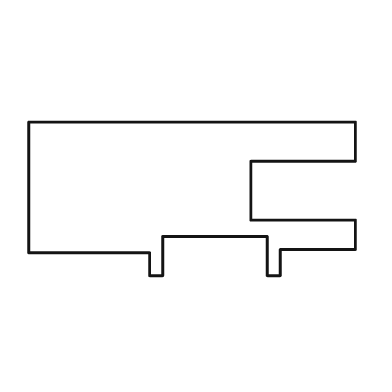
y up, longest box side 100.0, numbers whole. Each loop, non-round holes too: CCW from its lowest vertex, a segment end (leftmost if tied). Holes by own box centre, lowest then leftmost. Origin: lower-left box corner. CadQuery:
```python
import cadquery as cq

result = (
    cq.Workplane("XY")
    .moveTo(37.0, 0.0)
    .lineTo(41.0, 0.0)
    .lineTo(41.0, 12.0)
    .lineTo(73.0, 12.0)
    .lineTo(73.0, 0.0)
    .lineTo(77.0, 0.0)
    .lineTo(77.0, 8.0)
    .lineTo(100.0, 8.0)
    .lineTo(100.0, 17.0)
    .lineTo(68.0, 17.0)
    .lineTo(68.0, 35.0)
    .lineTo(100.0, 35.0)
    .lineTo(100.0, 47.0)
    .lineTo(0.0, 47.0)
    .lineTo(0.0, 7.0)
    .lineTo(37.0, 7.0)
    .close()
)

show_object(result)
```